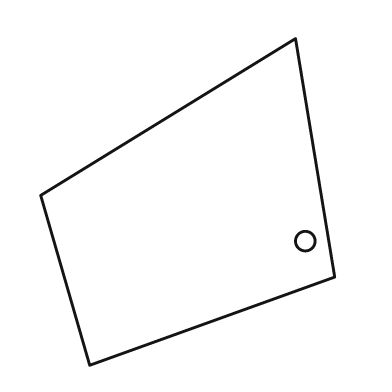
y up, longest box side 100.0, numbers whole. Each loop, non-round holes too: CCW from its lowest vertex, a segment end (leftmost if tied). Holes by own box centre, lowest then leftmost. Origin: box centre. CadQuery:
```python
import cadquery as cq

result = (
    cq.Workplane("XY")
    .moveTo(-30.0, -50.0)
    .lineTo(45.0, -23.0)
    .lineTo(33.0, 50.0)
    .lineTo(-45.0, 2.0)
    .close()
    .moveTo(36.0, -12.0)
    .circle(3.0)
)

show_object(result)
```